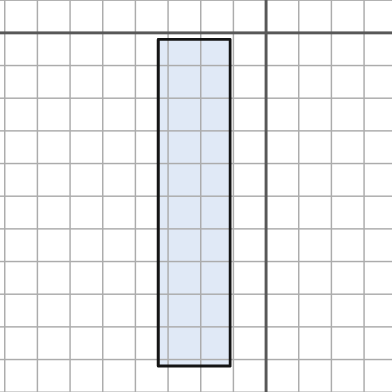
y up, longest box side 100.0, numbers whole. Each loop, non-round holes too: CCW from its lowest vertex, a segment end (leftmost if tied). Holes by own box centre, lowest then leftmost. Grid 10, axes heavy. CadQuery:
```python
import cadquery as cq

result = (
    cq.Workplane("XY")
    .moveTo(-33.0, -102.0)
    .lineTo(-11.0, -102.0)
    .lineTo(-11.0, -2.0)
    .lineTo(-33.0, -2.0)
    .close()
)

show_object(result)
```